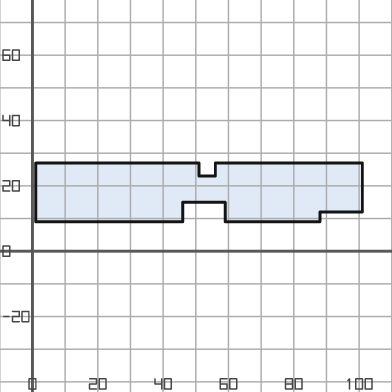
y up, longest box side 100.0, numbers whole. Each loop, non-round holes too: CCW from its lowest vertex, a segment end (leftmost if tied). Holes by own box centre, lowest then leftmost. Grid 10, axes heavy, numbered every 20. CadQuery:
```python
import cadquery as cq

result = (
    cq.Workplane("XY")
    .moveTo(1.0, 9.0)
    .lineTo(46.0, 9.0)
    .lineTo(46.0, 15.0)
    .lineTo(59.0, 15.0)
    .lineTo(59.0, 9.0)
    .lineTo(88.0, 9.0)
    .lineTo(88.0, 12.0)
    .lineTo(101.0, 12.0)
    .lineTo(101.0, 27.0)
    .lineTo(56.0, 27.0)
    .lineTo(56.0, 23.0)
    .lineTo(51.0, 23.0)
    .lineTo(51.0, 27.0)
    .lineTo(1.0, 27.0)
    .close()
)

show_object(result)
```